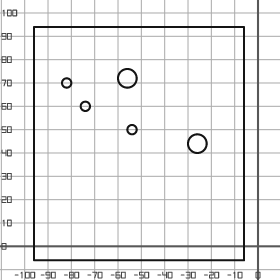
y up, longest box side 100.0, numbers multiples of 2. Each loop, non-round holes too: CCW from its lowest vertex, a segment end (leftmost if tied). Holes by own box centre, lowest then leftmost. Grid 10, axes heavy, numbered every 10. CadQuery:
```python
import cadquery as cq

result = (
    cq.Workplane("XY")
    .moveTo(-96.0, -6.0)
    .lineTo(-6.0, -6.0)
    .lineTo(-6.0, 94.0)
    .lineTo(-96.0, 94.0)
    .close()
    .moveTo(-26.0, 44.0)
    .circle(4.0)
    .moveTo(-54.0, 50.0)
    .circle(2.0)
    .moveTo(-74.0, 60.0)
    .circle(2.0)
    .moveTo(-82.0, 70.0)
    .circle(2.0)
    .moveTo(-56.0, 72.0)
    .circle(4.0)
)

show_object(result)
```